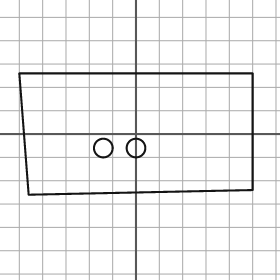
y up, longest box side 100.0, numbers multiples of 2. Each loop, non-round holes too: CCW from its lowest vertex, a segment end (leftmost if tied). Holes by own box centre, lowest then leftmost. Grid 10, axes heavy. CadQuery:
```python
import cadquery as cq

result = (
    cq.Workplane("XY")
    .moveTo(-46.0, -26.0)
    .lineTo(50.0, -24.0)
    .lineTo(50.0, 26.0)
    .lineTo(-50.0, 26.0)
    .close()
    .moveTo(-14.0, -6.0)
    .circle(4.0)
    .moveTo(0.0, -6.0)
    .circle(4.0)
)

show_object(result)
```